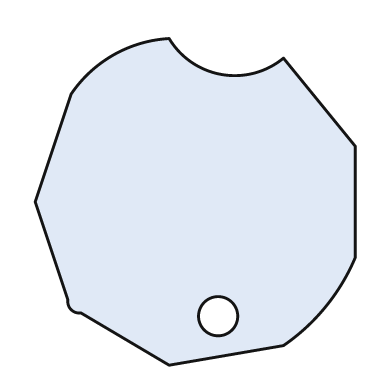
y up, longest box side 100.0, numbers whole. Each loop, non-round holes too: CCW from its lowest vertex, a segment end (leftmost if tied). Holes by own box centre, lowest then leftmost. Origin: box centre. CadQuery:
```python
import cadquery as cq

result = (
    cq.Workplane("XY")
    .moveTo(-8.0, -50.0)
    .lineTo(27.0, -44.0)
    .threePointArc((40.0, -32.0), (49.0, -17.0))
    .lineTo(49.0, 17.0)
    .lineTo(27.0, 44.0)
    .threePointArc((8.0, 39.0), (-8.0, 50.0))
    .threePointArc((-25.0, 45.0), (-38.0, 33.0))
    .lineTo(-49.0, 0.0)
    .lineTo(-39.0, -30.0)
    .threePointArc((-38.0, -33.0), (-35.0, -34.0))
    .close()
    .moveTo(7.0, -35.0)
    .circle(6.0)
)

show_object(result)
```